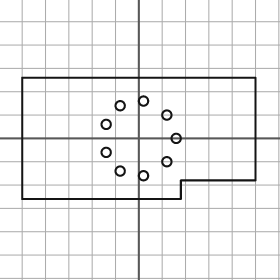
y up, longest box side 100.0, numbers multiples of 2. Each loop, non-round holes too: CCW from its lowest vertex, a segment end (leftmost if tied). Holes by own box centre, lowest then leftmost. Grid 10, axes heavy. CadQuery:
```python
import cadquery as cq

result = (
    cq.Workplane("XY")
    .moveTo(-50.0, -26.0)
    .lineTo(18.0, -26.0)
    .lineTo(18.0, -18.0)
    .lineTo(50.0, -18.0)
    .lineTo(50.0, 26.0)
    .lineTo(-50.0, 26.0)
    .close()
    .moveTo(2.0, -16.0)
    .circle(2.0)
    .moveTo(-8.0, -14.0)
    .circle(2.0)
    .moveTo(12.0, -10.0)
    .circle(2.0)
    .moveTo(-14.0, -6.0)
    .circle(2.0)
    .moveTo(16.0, 0.0)
    .circle(2.0)
    .moveTo(-14.0, 6.0)
    .circle(2.0)
    .moveTo(12.0, 10.0)
    .circle(2.0)
    .moveTo(-8.0, 14.0)
    .circle(2.0)
    .moveTo(2.0, 16.0)
    .circle(2.0)
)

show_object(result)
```